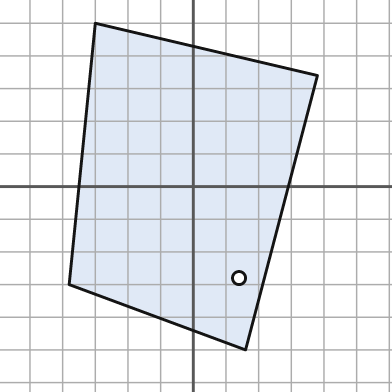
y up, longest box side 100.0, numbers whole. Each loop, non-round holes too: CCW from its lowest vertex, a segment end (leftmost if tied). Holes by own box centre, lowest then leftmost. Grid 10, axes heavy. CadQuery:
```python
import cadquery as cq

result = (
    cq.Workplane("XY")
    .moveTo(16.0, -50.0)
    .lineTo(38.0, 34.0)
    .lineTo(-30.0, 50.0)
    .lineTo(-38.0, -30.0)
    .close()
    .moveTo(14.0, -28.0)
    .circle(2.0)
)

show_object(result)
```